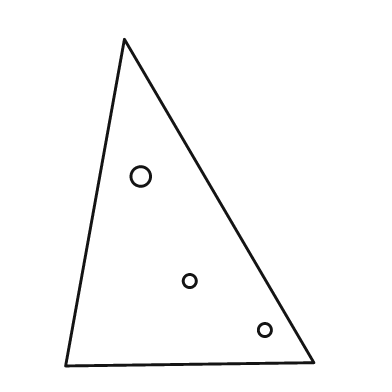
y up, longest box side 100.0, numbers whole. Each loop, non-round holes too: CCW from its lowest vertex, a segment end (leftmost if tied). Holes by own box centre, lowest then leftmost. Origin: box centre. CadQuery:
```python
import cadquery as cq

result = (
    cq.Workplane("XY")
    .moveTo(-38.0, -50.0)
    .lineTo(38.0, -49.0)
    .lineTo(-20.0, 50.0)
    .close()
    .moveTo(23.0, -39.0)
    .circle(2.0)
    .moveTo(0.0, -24.0)
    .circle(2.0)
    .moveTo(-15.0, 8.0)
    .circle(3.0)
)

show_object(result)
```